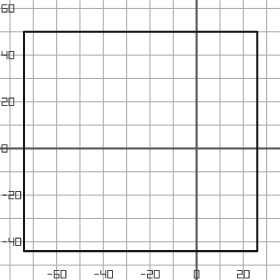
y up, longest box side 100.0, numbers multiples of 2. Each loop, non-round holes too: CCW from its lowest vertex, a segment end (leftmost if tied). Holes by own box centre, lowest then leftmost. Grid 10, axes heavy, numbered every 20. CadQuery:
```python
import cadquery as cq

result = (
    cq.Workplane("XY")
    .moveTo(-74.0, -44.0)
    .lineTo(26.0, -44.0)
    .lineTo(26.0, 50.0)
    .lineTo(-74.0, 50.0)
    .close()
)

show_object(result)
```